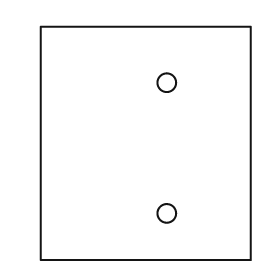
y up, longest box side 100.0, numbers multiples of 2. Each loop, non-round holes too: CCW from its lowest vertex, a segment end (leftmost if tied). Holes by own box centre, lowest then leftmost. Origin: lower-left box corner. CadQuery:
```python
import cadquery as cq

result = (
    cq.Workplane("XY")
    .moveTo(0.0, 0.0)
    .lineTo(90.0, 0.0)
    .lineTo(90.0, 100.0)
    .lineTo(0.0, 100.0)
    .close()
    .moveTo(54.0, 20.0)
    .circle(4.0)
    .moveTo(54.0, 76.0)
    .circle(4.0)
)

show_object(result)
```